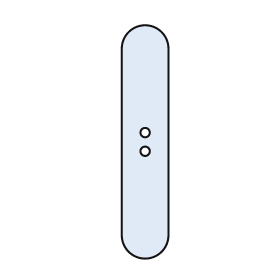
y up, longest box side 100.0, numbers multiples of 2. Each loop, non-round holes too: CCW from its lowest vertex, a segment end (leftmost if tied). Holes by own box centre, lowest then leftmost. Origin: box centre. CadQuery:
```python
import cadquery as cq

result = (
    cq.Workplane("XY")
    .moveTo(-10.0, -40.0)
    .threePointArc((0.0, -50.0), (10.0, -40.0))
    .lineTo(10.0, 40.0)
    .threePointArc((0.0, 50.0), (-10.0, 40.0))
    .close()
    .moveTo(0.0, -4.0)
    .circle(2.0)
    .moveTo(0.0, 4.0)
    .circle(2.0)
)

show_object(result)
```